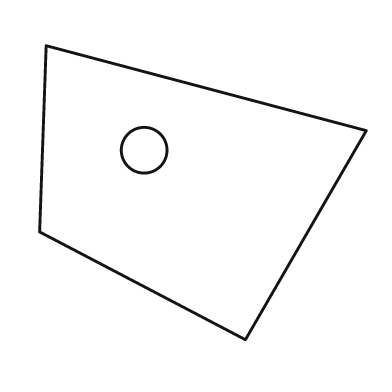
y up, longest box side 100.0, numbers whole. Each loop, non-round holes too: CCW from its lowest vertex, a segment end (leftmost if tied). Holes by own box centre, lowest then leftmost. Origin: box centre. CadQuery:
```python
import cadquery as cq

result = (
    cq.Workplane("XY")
    .moveTo(13.0, -45.0)
    .lineTo(50.0, 19.0)
    .lineTo(-48.0, 45.0)
    .lineTo(-50.0, -12.0)
    .close()
    .moveTo(-18.0, 13.0)
    .circle(7.0)
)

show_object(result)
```